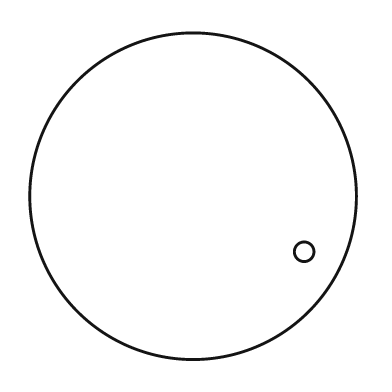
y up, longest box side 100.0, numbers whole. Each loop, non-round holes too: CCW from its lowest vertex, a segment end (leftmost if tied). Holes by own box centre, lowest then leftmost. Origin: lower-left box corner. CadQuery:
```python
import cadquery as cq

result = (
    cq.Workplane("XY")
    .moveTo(50.0, 50.0)
    .circle(50.0)
    .moveTo(84.0, 33.0)
    .circle(3.0)
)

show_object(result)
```